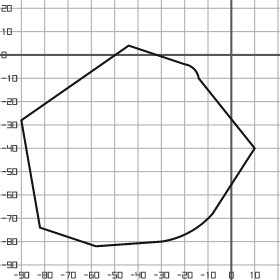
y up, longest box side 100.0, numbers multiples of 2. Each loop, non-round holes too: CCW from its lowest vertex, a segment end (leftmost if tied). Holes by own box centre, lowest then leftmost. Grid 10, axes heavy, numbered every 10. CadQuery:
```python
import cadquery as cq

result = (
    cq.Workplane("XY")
    .moveTo(-58.0, -82.0)
    .lineTo(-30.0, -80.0)
    .threePointArc((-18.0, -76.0), (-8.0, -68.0))
    .lineTo(10.0, -40.0)
    .lineTo(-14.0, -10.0)
    .threePointArc((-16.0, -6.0), (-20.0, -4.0))
    .lineTo(-44.0, 4.0)
    .lineTo(-90.0, -28.0)
    .lineTo(-82.0, -74.0)
    .close()
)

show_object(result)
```